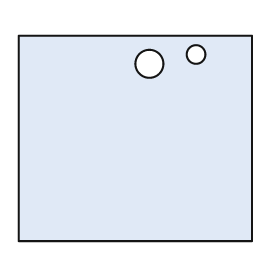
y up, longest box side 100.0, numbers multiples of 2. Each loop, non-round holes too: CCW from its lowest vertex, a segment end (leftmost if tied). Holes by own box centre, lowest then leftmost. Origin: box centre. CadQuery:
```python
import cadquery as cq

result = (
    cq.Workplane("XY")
    .moveTo(-50.0, -44.0)
    .lineTo(50.0, -44.0)
    .lineTo(50.0, 44.0)
    .lineTo(-50.0, 44.0)
    .close()
    .moveTo(6.0, 32.0)
    .circle(6.0)
    .moveTo(26.0, 36.0)
    .circle(4.0)
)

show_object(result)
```